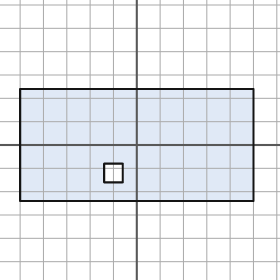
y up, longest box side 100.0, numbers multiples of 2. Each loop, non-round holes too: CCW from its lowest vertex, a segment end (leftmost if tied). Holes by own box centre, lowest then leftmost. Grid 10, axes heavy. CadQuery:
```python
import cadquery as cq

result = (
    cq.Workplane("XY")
    .moveTo(-50.0, -24.0)
    .lineTo(50.0, -24.0)
    .lineTo(50.0, 24.0)
    .lineTo(-50.0, 24.0)
    .close()
    .moveTo(-14.0, -16.0)
    .lineTo(-6.0, -16.0)
    .lineTo(-6.0, -8.0)
    .lineTo(-14.0, -8.0)
    .close()
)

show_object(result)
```